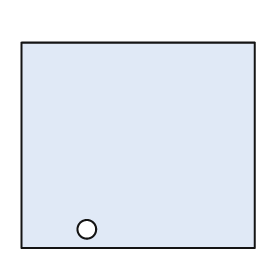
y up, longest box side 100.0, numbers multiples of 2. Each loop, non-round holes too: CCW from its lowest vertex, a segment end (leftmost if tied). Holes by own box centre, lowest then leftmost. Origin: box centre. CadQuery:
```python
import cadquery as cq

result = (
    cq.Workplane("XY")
    .moveTo(-50.0, -44.0)
    .lineTo(50.0, -44.0)
    .lineTo(50.0, 44.0)
    .lineTo(-50.0, 44.0)
    .close()
    .moveTo(-22.0, -36.0)
    .circle(4.0)
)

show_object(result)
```